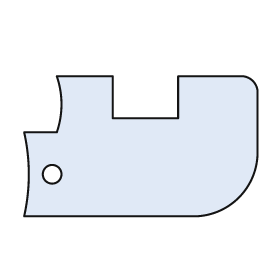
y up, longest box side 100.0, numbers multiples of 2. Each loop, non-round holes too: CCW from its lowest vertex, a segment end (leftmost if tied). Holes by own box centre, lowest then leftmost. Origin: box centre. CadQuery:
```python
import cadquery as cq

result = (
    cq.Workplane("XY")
    .moveTo(-50.0, -30.0)
    .lineTo(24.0, -30.0)
    .threePointArc((42.0, -22.0), (50.0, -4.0))
    .lineTo(50.0, 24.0)
    .threePointArc((48.0, 28.0), (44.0, 30.0))
    .lineTo(16.0, 30.0)
    .lineTo(16.0, 12.0)
    .lineTo(-12.0, 12.0)
    .lineTo(-12.0, 30.0)
    .lineTo(-36.0, 30.0)
    .threePointArc((-34.0, 18.0), (-36.0, 6.0))
    .lineTo(-50.0, 6.0)
    .threePointArc((-48.0, -12.0), (-50.0, -30.0))
    .close()
    .moveTo(-38.0, -12.0)
    .circle(4.0)
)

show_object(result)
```